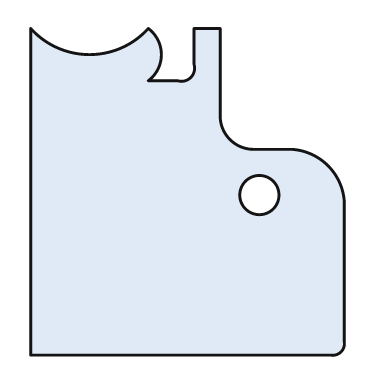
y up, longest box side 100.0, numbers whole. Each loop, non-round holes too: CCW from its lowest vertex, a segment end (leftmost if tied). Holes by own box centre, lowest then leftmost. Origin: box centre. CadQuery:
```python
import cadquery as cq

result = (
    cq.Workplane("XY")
    .moveTo(-48.0, -50.0)
    .lineTo(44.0, -50.0)
    .threePointArc((47.0, -49.0), (48.0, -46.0))
    .lineTo(48.0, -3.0)
    .threePointArc((43.0, 8.0), (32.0, 13.0))
    .lineTo(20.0, 13.0)
    .threePointArc((13.0, 16.0), (10.0, 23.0))
    .lineTo(10.0, 50.0)
    .lineTo(2.0, 50.0)
    .lineTo(2.0, 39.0)
    .threePointArc((1.0, 35.0), (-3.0, 34.0))
    .lineTo(-12.0, 34.0)
    .threePointArc((-8.0, 42.0), (-12.0, 50.0))
    .threePointArc((-30.0, 42.0), (-48.0, 50.0))
    .close()
    .moveTo(22.0, -1.0)
    .circle(6.0)
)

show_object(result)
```